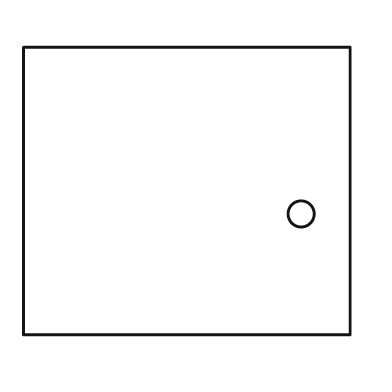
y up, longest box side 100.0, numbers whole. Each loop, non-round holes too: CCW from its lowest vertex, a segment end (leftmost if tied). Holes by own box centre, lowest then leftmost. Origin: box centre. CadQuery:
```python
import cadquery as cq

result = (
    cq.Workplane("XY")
    .moveTo(-50.0, -44.0)
    .lineTo(50.0, -44.0)
    .lineTo(50.0, 44.0)
    .lineTo(-50.0, 44.0)
    .close()
    .moveTo(35.0, -7.0)
    .circle(4.0)
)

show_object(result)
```